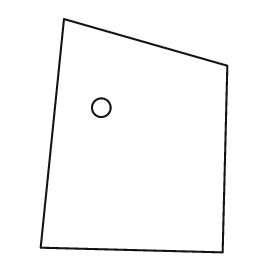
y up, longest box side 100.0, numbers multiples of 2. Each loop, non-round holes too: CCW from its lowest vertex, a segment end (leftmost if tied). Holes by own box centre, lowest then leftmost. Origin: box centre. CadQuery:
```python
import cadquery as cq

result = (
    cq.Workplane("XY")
    .moveTo(38.0, -50.0)
    .lineTo(40.0, 30.0)
    .lineTo(-30.0, 50.0)
    .lineTo(-40.0, -48.0)
    .close()
    .moveTo(-14.0, 12.0)
    .circle(4.0)
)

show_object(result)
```